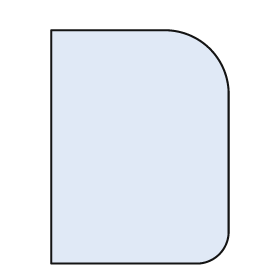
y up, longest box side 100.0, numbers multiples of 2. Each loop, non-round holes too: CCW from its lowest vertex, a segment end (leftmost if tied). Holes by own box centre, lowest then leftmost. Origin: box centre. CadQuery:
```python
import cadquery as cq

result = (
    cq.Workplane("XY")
    .moveTo(-38.0, -50.0)
    .lineTo(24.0, -50.0)
    .threePointArc((34.0, -46.0), (38.0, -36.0))
    .lineTo(38.0, 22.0)
    .threePointArc((30.0, 42.0), (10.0, 50.0))
    .lineTo(-38.0, 50.0)
    .close()
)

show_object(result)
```